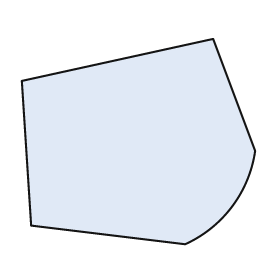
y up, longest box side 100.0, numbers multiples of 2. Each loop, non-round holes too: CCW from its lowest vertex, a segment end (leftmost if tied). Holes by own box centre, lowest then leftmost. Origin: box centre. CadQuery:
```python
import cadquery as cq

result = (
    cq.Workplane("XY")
    .moveTo(20.0, -44.0)
    .threePointArc((40.0, -28.0), (50.0, -4.0))
    .lineTo(32.0, 44.0)
    .lineTo(-50.0, 26.0)
    .lineTo(-46.0, -36.0)
    .close()
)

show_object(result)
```